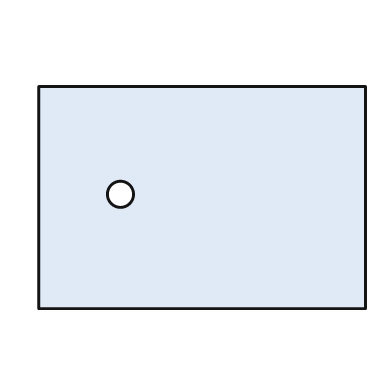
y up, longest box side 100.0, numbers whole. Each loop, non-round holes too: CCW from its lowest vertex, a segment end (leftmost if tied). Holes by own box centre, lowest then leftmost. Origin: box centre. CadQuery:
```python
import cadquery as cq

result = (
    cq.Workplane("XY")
    .moveTo(-50.0, -34.0)
    .lineTo(50.0, -34.0)
    .lineTo(50.0, 34.0)
    .lineTo(-50.0, 34.0)
    .close()
    .moveTo(-25.0, 1.0)
    .circle(4.0)
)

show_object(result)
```